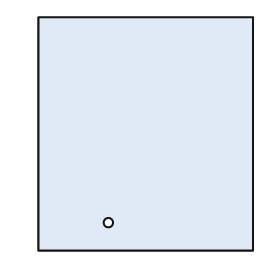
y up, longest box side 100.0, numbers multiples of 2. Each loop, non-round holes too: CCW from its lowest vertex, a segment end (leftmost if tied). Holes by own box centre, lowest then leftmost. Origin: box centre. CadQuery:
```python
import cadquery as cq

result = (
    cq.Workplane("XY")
    .moveTo(-46.0, -50.0)
    .lineTo(46.0, -50.0)
    .lineTo(46.0, 50.0)
    .lineTo(-46.0, 50.0)
    .close()
    .moveTo(-16.0, -38.0)
    .circle(2.0)
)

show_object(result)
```